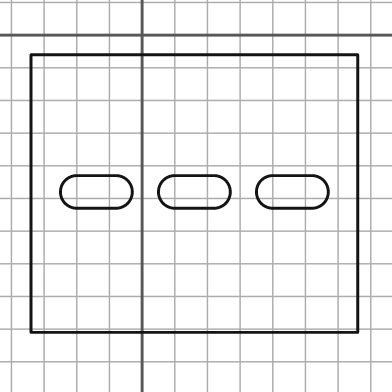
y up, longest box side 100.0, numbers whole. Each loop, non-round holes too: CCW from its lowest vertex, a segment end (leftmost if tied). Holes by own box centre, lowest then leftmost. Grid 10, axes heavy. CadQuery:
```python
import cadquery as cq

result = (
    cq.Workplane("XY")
    .moveTo(-34.0, -91.0)
    .lineTo(66.0, -91.0)
    .lineTo(66.0, -6.0)
    .lineTo(-34.0, -6.0)
    .close()
    .moveTo(-20.0, -53.0)
    .lineTo(-8.0, -53.0)
    .threePointArc((-3.0, -48.0), (-8.0, -43.0))
    .lineTo(-20.0, -43.0)
    .threePointArc((-25.0, -48.0), (-20.0, -53.0))
    .close()
    .moveTo(10.0, -53.0)
    .lineTo(22.0, -53.0)
    .threePointArc((27.0, -48.0), (22.0, -43.0))
    .lineTo(10.0, -43.0)
    .threePointArc((5.0, -48.0), (10.0, -53.0))
    .close()
    .moveTo(40.0, -53.0)
    .lineTo(52.0, -53.0)
    .threePointArc((57.0, -48.0), (52.0, -43.0))
    .lineTo(40.0, -43.0)
    .threePointArc((35.0, -48.0), (40.0, -53.0))
    .close()
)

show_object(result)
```